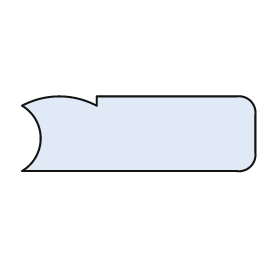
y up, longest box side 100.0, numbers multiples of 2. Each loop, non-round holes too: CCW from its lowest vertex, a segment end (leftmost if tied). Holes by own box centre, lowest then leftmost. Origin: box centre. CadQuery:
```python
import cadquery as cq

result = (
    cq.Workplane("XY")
    .moveTo(-50.0, -16.0)
    .lineTo(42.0, -16.0)
    .threePointArc((48.0, -14.0), (50.0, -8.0))
    .lineTo(50.0, 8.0)
    .threePointArc((48.0, 14.0), (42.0, 16.0))
    .lineTo(-18.0, 16.0)
    .lineTo(-18.0, 12.0)
    .threePointArc((-34.0, 16.0), (-50.0, 12.0))
    .threePointArc((-42.0, -2.0), (-50.0, -16.0))
    .close()
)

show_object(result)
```